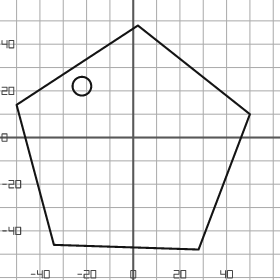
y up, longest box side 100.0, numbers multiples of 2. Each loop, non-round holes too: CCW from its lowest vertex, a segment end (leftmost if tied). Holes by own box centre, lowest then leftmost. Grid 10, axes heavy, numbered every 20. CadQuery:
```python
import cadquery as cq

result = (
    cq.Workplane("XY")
    .moveTo(28.0, -48.0)
    .lineTo(50.0, 10.0)
    .lineTo(2.0, 48.0)
    .lineTo(-50.0, 14.0)
    .lineTo(-34.0, -46.0)
    .close()
    .moveTo(-22.0, 22.0)
    .circle(4.0)
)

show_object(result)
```